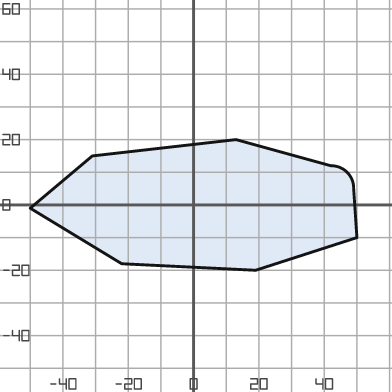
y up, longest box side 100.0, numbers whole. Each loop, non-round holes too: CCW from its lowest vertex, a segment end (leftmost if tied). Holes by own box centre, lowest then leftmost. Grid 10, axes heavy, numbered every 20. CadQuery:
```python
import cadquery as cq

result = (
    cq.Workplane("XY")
    .moveTo(19.0, -20.0)
    .lineTo(50.0, -10.0)
    .lineTo(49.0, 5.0)
    .threePointArc((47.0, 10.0), (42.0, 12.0))
    .lineTo(13.0, 20.0)
    .lineTo(-31.0, 15.0)
    .lineTo(-50.0, -1.0)
    .lineTo(-22.0, -18.0)
    .close()
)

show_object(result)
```